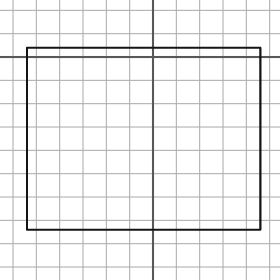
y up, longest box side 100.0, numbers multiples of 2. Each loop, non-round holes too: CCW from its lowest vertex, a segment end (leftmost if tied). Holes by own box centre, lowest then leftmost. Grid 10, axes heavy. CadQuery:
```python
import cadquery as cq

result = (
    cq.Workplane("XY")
    .moveTo(-54.0, -74.0)
    .lineTo(46.0, -74.0)
    .lineTo(46.0, 4.0)
    .lineTo(-54.0, 4.0)
    .close()
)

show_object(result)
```